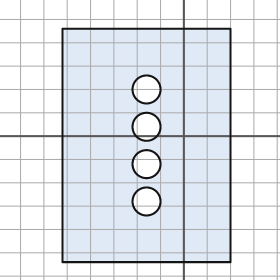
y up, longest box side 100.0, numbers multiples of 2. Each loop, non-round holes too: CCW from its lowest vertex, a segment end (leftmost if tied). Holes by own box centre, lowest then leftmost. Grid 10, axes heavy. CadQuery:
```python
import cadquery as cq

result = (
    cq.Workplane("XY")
    .moveTo(-52.0, -54.0)
    .lineTo(20.0, -54.0)
    .lineTo(20.0, 46.0)
    .lineTo(-52.0, 46.0)
    .close()
    .moveTo(-16.0, -28.0)
    .circle(6.0)
    .moveTo(-16.0, -12.0)
    .circle(6.0)
    .moveTo(-16.0, 4.0)
    .circle(6.0)
    .moveTo(-16.0, 20.0)
    .circle(6.0)
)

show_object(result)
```